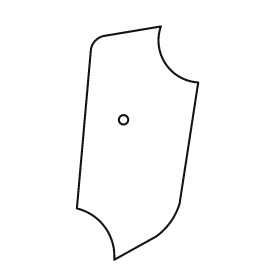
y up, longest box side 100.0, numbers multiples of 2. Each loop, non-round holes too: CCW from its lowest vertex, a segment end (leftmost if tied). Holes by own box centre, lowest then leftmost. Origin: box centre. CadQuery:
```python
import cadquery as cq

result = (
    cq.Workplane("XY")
    .moveTo(-10.0, -50.0)
    .lineTo(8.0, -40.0)
    .threePointArc((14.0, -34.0), (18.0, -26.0))
    .lineTo(26.0, 26.0)
    .threePointArc((12.0, 34.0), (10.0, 50.0))
    .lineTo(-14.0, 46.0)
    .threePointArc((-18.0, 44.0), (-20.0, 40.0))
    .lineTo(-26.0, -28.0)
    .threePointArc((-14.0, -36.0), (-10.0, -50.0))
    .close()
    .moveTo(-6.0, 10.0)
    .circle(2.0)
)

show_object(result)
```